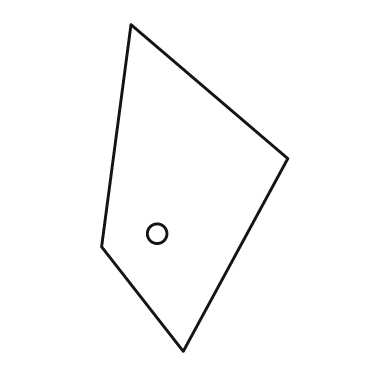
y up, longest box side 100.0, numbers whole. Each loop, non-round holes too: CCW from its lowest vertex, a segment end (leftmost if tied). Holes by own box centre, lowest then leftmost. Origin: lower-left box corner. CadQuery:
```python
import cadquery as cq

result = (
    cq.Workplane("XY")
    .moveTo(25.0, 0.0)
    .lineTo(57.0, 59.0)
    .lineTo(9.0, 100.0)
    .lineTo(0.0, 32.0)
    .close()
    .moveTo(17.0, 36.0)
    .circle(3.0)
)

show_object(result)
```